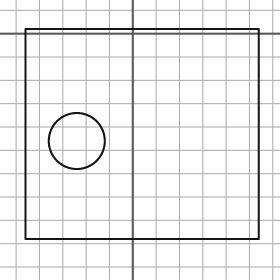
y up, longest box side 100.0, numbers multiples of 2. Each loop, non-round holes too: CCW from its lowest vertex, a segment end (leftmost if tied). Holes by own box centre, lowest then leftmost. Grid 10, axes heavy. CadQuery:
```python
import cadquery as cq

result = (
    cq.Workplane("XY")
    .moveTo(-46.0, -88.0)
    .lineTo(54.0, -88.0)
    .lineTo(54.0, 2.0)
    .lineTo(-46.0, 2.0)
    .close()
    .moveTo(-24.0, -46.0)
    .circle(12.0)
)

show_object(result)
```